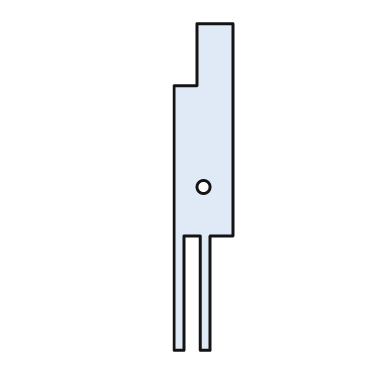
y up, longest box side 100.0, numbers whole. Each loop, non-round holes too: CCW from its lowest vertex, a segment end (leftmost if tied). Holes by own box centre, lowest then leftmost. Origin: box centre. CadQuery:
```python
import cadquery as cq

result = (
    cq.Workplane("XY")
    .moveTo(-9.0, -50.0)
    .lineTo(-6.0, -50.0)
    .lineTo(-6.0, -15.0)
    .lineTo(-1.0, -15.0)
    .lineTo(-1.0, -50.0)
    .lineTo(2.0, -50.0)
    .lineTo(2.0, -15.0)
    .lineTo(9.0, -15.0)
    .lineTo(9.0, 50.0)
    .lineTo(-2.0, 50.0)
    .lineTo(-2.0, 31.0)
    .lineTo(-9.0, 31.0)
    .close()
    .moveTo(0.0, 0.0)
    .circle(2.0)
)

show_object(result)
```